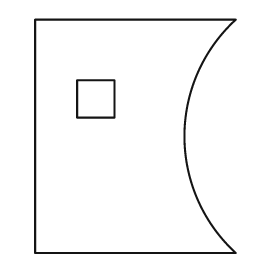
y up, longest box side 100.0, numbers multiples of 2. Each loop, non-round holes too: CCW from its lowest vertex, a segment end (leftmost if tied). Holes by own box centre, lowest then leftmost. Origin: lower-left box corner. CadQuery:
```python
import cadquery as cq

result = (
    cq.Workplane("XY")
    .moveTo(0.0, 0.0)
    .lineTo(86.0, 0.0)
    .threePointArc((64.0, 50.0), (86.0, 100.0))
    .lineTo(0.0, 100.0)
    .close()
    .moveTo(18.0, 58.0)
    .lineTo(34.0, 58.0)
    .lineTo(34.0, 74.0)
    .lineTo(18.0, 74.0)
    .close()
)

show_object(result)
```